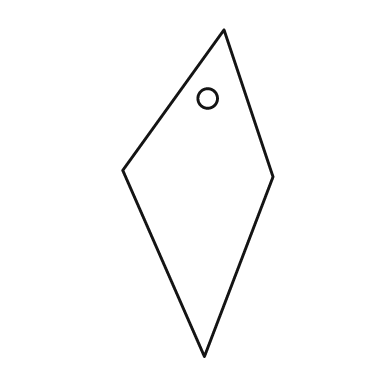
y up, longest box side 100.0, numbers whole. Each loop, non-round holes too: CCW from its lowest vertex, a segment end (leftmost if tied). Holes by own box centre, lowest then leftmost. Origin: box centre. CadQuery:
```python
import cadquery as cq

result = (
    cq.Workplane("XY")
    .moveTo(2.0, -50.0)
    .lineTo(23.0, 5.0)
    .lineTo(8.0, 50.0)
    .lineTo(-23.0, 7.0)
    .close()
    .moveTo(3.0, 29.0)
    .circle(3.0)
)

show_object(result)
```